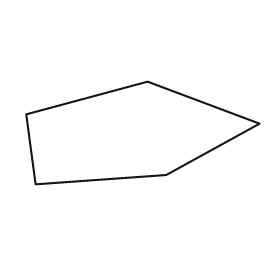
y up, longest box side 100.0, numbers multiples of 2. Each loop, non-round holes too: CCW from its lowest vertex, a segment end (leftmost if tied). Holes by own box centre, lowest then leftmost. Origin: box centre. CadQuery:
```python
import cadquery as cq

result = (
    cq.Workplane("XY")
    .moveTo(-46.0, -22.0)
    .lineTo(10.0, -18.0)
    .lineTo(50.0, 4.0)
    .lineTo(2.0, 22.0)
    .lineTo(-50.0, 8.0)
    .close()
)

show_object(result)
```